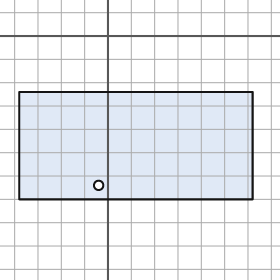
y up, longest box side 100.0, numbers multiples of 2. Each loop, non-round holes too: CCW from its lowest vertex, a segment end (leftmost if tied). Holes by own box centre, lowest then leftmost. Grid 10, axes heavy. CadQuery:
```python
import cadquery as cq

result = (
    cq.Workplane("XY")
    .moveTo(-38.0, -70.0)
    .lineTo(62.0, -70.0)
    .lineTo(62.0, -24.0)
    .lineTo(-38.0, -24.0)
    .close()
    .moveTo(-4.0, -64.0)
    .circle(2.0)
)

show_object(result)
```